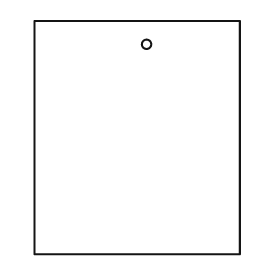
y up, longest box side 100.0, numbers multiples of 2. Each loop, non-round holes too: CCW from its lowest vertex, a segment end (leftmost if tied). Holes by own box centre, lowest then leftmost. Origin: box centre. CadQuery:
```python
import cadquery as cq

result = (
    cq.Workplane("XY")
    .moveTo(-44.0, -50.0)
    .lineTo(44.0, -50.0)
    .lineTo(44.0, 50.0)
    .lineTo(-44.0, 50.0)
    .close()
    .moveTo(4.0, 40.0)
    .circle(2.0)
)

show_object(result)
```